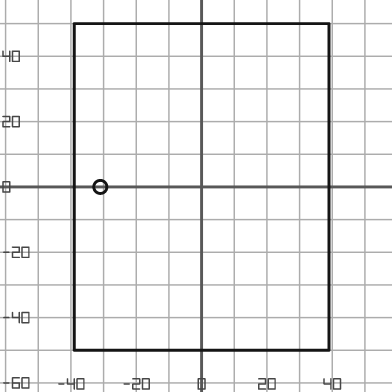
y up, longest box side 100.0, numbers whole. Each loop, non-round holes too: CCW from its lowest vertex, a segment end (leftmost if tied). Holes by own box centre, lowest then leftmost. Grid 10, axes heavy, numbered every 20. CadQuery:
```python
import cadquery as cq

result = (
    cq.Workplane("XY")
    .moveTo(-39.0, -50.0)
    .lineTo(39.0, -50.0)
    .lineTo(39.0, 50.0)
    .lineTo(-39.0, 50.0)
    .close()
    .moveTo(-31.0, 0.0)
    .circle(2.0)
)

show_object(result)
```